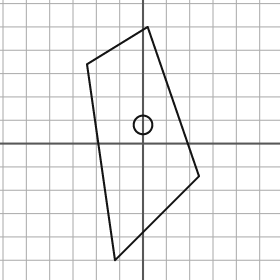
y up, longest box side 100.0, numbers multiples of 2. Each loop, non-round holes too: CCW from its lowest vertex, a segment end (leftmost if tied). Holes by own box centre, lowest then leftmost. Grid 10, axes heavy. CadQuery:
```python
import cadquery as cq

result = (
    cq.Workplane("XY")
    .moveTo(-12.0, -50.0)
    .lineTo(24.0, -14.0)
    .lineTo(2.0, 50.0)
    .lineTo(-24.0, 34.0)
    .close()
    .moveTo(0.0, 8.0)
    .circle(4.0)
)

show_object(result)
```